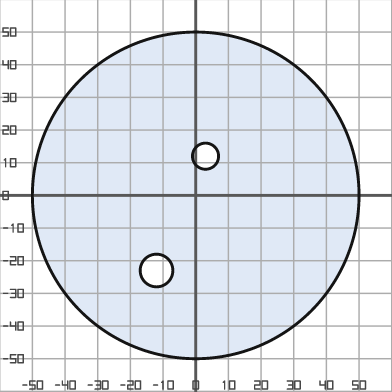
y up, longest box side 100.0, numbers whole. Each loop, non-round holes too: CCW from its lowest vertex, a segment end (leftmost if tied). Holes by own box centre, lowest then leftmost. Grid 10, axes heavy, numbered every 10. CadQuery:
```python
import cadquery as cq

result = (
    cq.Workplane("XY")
    .moveTo(0.0, 0.0)
    .circle(50.0)
    .moveTo(-12.0, -23.0)
    .circle(5.0)
    .moveTo(3.0, 12.0)
    .circle(4.0)
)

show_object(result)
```